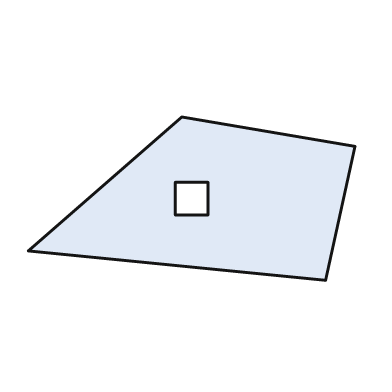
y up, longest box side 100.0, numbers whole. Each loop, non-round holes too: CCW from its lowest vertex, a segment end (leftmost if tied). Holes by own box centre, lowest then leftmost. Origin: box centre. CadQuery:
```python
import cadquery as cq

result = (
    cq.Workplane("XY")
    .moveTo(41.0, -25.0)
    .lineTo(50.0, 16.0)
    .lineTo(-3.0, 25.0)
    .lineTo(-50.0, -16.0)
    .close()
    .moveTo(-5.0, -5.0)
    .lineTo(5.0, -5.0)
    .lineTo(5.0, 5.0)
    .lineTo(-5.0, 5.0)
    .close()
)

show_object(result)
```